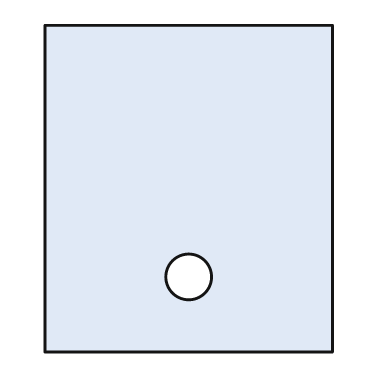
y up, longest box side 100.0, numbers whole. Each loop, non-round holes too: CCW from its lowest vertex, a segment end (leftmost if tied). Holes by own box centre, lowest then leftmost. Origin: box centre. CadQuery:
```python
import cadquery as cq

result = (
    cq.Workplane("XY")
    .moveTo(-44.0, -50.0)
    .lineTo(44.0, -50.0)
    .lineTo(44.0, 50.0)
    .lineTo(-44.0, 50.0)
    .close()
    .moveTo(0.0, -27.0)
    .circle(7.0)
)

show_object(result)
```